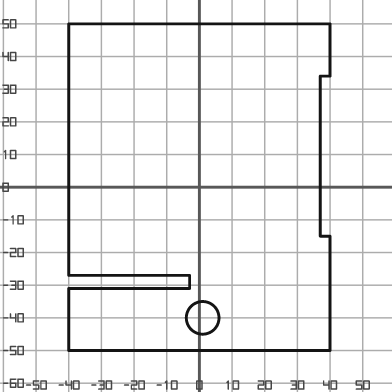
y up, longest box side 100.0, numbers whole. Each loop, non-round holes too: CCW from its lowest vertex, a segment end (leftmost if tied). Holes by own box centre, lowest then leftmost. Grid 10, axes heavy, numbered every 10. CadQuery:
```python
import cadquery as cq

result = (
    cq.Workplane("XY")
    .moveTo(-40.0, -50.0)
    .lineTo(40.0, -50.0)
    .lineTo(40.0, -15.0)
    .lineTo(37.0, -15.0)
    .lineTo(37.0, 34.0)
    .lineTo(40.0, 34.0)
    .lineTo(40.0, 50.0)
    .lineTo(-40.0, 50.0)
    .lineTo(-40.0, -27.0)
    .lineTo(-3.0, -27.0)
    .lineTo(-3.0, -31.0)
    .lineTo(-40.0, -31.0)
    .close()
    .moveTo(1.0, -40.0)
    .circle(5.0)
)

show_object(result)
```